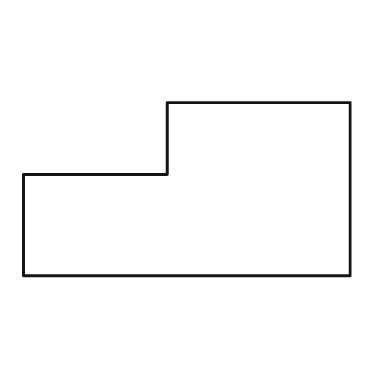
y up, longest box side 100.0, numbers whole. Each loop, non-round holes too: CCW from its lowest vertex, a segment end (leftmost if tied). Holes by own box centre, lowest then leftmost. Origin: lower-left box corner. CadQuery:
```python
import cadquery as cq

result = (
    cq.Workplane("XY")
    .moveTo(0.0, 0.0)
    .lineTo(100.0, 0.0)
    .lineTo(100.0, 53.0)
    .lineTo(44.0, 53.0)
    .lineTo(44.0, 31.0)
    .lineTo(0.0, 31.0)
    .close()
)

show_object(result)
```